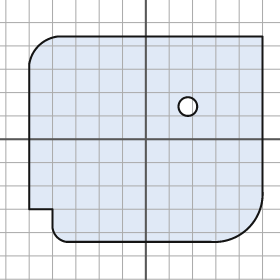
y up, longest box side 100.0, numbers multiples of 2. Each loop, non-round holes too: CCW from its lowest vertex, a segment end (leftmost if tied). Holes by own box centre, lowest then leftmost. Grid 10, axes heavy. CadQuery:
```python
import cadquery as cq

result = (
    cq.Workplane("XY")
    .moveTo(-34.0, -44.0)
    .lineTo(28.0, -44.0)
    .threePointArc((44.0, -38.0), (50.0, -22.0))
    .lineTo(50.0, 44.0)
    .lineTo(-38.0, 44.0)
    .threePointArc((-46.0, 40.0), (-50.0, 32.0))
    .lineTo(-50.0, -30.0)
    .lineTo(-40.0, -30.0)
    .lineTo(-40.0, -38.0)
    .threePointArc((-38.0, -42.0), (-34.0, -44.0))
    .close()
    .moveTo(18.0, 14.0)
    .circle(4.0)
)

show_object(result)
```